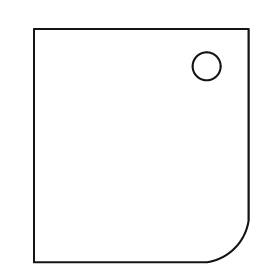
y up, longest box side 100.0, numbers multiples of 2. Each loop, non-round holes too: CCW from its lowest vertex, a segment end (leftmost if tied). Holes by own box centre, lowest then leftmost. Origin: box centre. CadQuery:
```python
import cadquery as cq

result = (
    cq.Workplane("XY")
    .moveTo(-46.0, -50.0)
    .lineTo(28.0, -50.0)
    .threePointArc((40.0, -44.0), (46.0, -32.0))
    .lineTo(46.0, 50.0)
    .lineTo(-46.0, 50.0)
    .close()
    .moveTo(28.0, 34.0)
    .circle(6.0)
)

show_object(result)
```